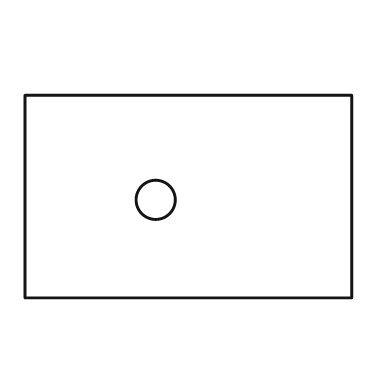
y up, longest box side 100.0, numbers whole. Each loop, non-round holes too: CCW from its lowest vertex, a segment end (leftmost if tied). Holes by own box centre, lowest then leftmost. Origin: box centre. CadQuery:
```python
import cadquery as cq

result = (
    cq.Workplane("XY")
    .moveTo(-50.0, -31.0)
    .lineTo(50.0, -31.0)
    .lineTo(50.0, 31.0)
    .lineTo(-50.0, 31.0)
    .close()
    .moveTo(-10.0, -1.0)
    .circle(6.0)
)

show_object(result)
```